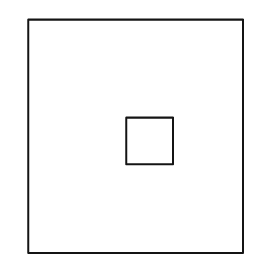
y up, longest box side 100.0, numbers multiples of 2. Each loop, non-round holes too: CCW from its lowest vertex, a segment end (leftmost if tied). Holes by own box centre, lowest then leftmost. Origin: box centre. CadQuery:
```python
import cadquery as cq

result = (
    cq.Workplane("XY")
    .moveTo(-46.0, -50.0)
    .lineTo(46.0, -50.0)
    .lineTo(46.0, 50.0)
    .lineTo(-46.0, 50.0)
    .close()
    .moveTo(-4.0, -12.0)
    .lineTo(16.0, -12.0)
    .lineTo(16.0, 8.0)
    .lineTo(-4.0, 8.0)
    .close()
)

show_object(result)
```